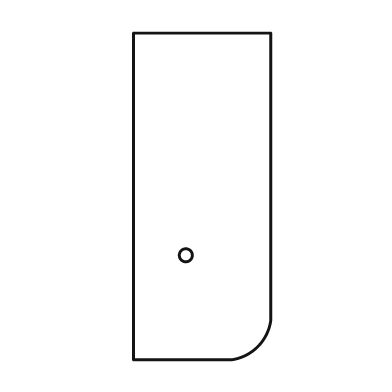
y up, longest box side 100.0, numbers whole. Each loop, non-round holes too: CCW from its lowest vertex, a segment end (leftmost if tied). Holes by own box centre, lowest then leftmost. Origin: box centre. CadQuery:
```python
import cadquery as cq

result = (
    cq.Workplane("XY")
    .moveTo(-21.0, -50.0)
    .lineTo(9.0, -50.0)
    .threePointArc((17.0, -46.0), (21.0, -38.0))
    .lineTo(21.0, 50.0)
    .lineTo(-21.0, 50.0)
    .close()
    .moveTo(-5.0, -18.0)
    .circle(2.0)
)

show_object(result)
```